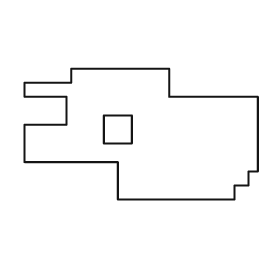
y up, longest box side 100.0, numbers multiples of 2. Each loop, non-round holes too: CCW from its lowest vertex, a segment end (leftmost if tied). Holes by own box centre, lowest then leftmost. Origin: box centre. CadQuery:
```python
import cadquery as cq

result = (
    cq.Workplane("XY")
    .moveTo(-10.0, -28.0)
    .lineTo(40.0, -28.0)
    .lineTo(40.0, -22.0)
    .lineTo(46.0, -22.0)
    .lineTo(46.0, -16.0)
    .lineTo(50.0, -16.0)
    .lineTo(50.0, 16.0)
    .lineTo(12.0, 16.0)
    .lineTo(12.0, 28.0)
    .lineTo(-30.0, 28.0)
    .lineTo(-30.0, 22.0)
    .lineTo(-50.0, 22.0)
    .lineTo(-50.0, 16.0)
    .lineTo(-32.0, 16.0)
    .lineTo(-32.0, 4.0)
    .lineTo(-50.0, 4.0)
    .lineTo(-50.0, -12.0)
    .lineTo(-10.0, -12.0)
    .close()
    .moveTo(-16.0, -4.0)
    .lineTo(-4.0, -4.0)
    .lineTo(-4.0, 8.0)
    .lineTo(-16.0, 8.0)
    .close()
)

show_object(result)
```